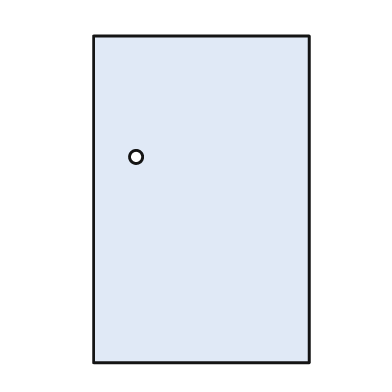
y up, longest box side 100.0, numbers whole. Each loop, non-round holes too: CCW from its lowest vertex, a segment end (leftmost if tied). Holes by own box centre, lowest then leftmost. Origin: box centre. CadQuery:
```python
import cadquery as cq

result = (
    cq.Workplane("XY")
    .moveTo(-33.0, -50.0)
    .lineTo(33.0, -50.0)
    .lineTo(33.0, 50.0)
    .lineTo(-33.0, 50.0)
    .close()
    .moveTo(-20.0, 13.0)
    .circle(2.0)
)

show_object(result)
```